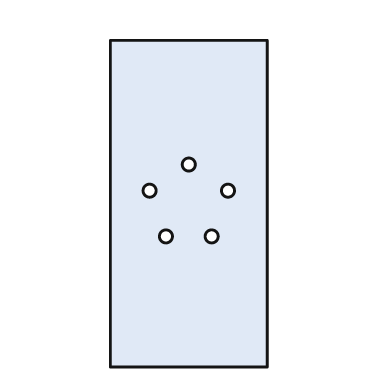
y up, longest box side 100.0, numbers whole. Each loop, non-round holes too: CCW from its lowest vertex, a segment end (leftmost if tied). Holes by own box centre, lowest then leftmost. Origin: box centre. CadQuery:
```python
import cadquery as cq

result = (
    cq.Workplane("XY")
    .moveTo(-24.0, -50.0)
    .lineTo(24.0, -50.0)
    .lineTo(24.0, 50.0)
    .lineTo(-24.0, 50.0)
    .close()
    .moveTo(-7.0, -10.0)
    .circle(2.0)
    .moveTo(7.0, -10.0)
    .circle(2.0)
    .moveTo(-12.0, 4.0)
    .circle(2.0)
    .moveTo(12.0, 4.0)
    .circle(2.0)
    .moveTo(0.0, 12.0)
    .circle(2.0)
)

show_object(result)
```